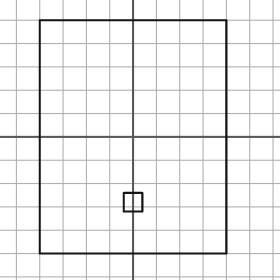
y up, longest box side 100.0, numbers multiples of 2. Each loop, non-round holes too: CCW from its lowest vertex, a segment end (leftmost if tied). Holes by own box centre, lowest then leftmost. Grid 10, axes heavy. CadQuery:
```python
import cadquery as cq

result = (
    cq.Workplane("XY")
    .moveTo(-40.0, -50.0)
    .lineTo(40.0, -50.0)
    .lineTo(40.0, 50.0)
    .lineTo(-40.0, 50.0)
    .close()
    .moveTo(-4.0, -32.0)
    .lineTo(4.0, -32.0)
    .lineTo(4.0, -24.0)
    .lineTo(-4.0, -24.0)
    .close()
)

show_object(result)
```